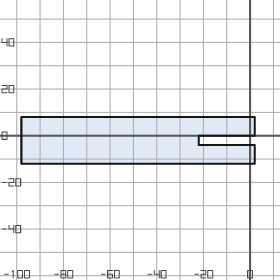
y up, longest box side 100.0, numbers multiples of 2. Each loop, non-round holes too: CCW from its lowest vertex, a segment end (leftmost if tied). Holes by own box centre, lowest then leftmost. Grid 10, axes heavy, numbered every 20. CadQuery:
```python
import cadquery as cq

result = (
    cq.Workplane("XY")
    .moveTo(-98.0, -12.0)
    .lineTo(2.0, -12.0)
    .lineTo(2.0, -4.0)
    .lineTo(-22.0, -4.0)
    .lineTo(-22.0, 0.0)
    .lineTo(2.0, 0.0)
    .lineTo(2.0, 8.0)
    .lineTo(-98.0, 8.0)
    .close()
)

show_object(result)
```